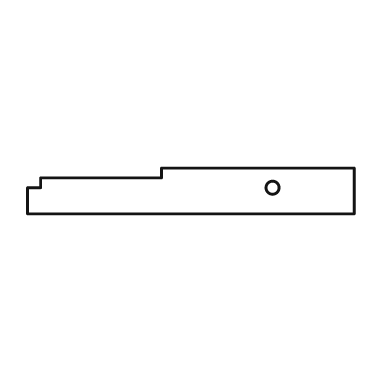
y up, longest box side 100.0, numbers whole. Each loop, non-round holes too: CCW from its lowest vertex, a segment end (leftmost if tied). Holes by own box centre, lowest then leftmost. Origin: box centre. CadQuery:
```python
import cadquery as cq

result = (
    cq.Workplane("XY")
    .moveTo(-50.0, -7.0)
    .lineTo(50.0, -7.0)
    .lineTo(50.0, 7.0)
    .lineTo(-9.0, 7.0)
    .lineTo(-9.0, 4.0)
    .lineTo(-46.0, 4.0)
    .lineTo(-46.0, 1.0)
    .lineTo(-50.0, 1.0)
    .close()
    .moveTo(25.0, 1.0)
    .circle(2.0)
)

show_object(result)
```